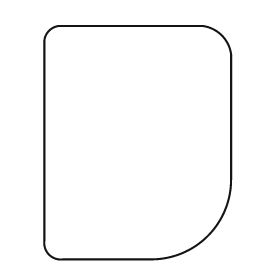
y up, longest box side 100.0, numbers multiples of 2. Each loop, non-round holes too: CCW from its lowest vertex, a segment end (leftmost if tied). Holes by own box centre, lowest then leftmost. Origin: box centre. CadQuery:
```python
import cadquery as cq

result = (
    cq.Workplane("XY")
    .moveTo(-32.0, -50.0)
    .lineTo(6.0, -50.0)
    .threePointArc((30.0, -40.0), (40.0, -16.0))
    .lineTo(40.0, 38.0)
    .threePointArc((36.0, 46.0), (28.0, 50.0))
    .lineTo(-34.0, 50.0)
    .threePointArc((-38.0, 48.0), (-40.0, 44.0))
    .lineTo(-40.0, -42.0)
    .threePointArc((-38.0, -48.0), (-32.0, -50.0))
    .close()
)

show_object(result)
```